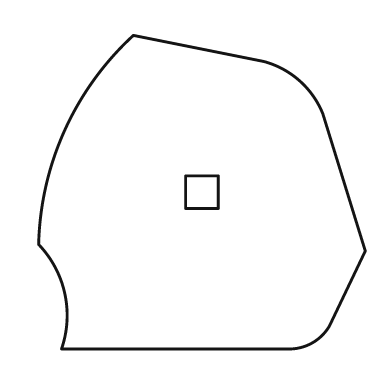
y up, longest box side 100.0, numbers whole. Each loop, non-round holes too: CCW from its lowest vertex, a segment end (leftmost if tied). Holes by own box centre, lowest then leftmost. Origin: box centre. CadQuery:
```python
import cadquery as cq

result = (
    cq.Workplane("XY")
    .moveTo(-43.0, -48.0)
    .lineTo(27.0, -48.0)
    .threePointArc((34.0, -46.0), (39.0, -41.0))
    .lineTo(50.0, -18.0)
    .lineTo(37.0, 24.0)
    .threePointArc((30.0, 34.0), (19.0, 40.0))
    .lineTo(-21.0, 48.0)
    .threePointArc((-42.0, 19.0), (-50.0, -16.0))
    .threePointArc((-42.0, -31.0), (-43.0, -48.0))
    .close()
    .moveTo(-5.0, -5.0)
    .lineTo(5.0, -5.0)
    .lineTo(5.0, 5.0)
    .lineTo(-5.0, 5.0)
    .close()
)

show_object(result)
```